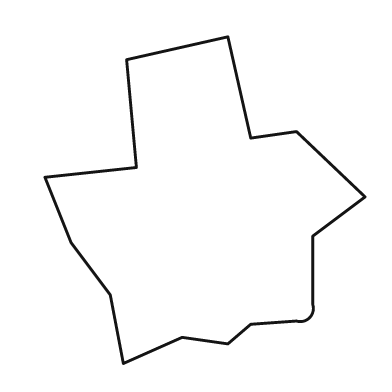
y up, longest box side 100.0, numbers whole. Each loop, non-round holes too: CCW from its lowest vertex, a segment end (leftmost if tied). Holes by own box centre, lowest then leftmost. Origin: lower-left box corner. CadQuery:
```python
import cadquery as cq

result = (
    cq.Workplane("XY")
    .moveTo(24.0, 0.0)
    .lineTo(42.0, 8.0)
    .lineTo(56.0, 6.0)
    .lineTo(63.0, 12.0)
    .lineTo(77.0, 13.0)
    .threePointArc((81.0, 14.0), (82.0, 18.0))
    .lineTo(82.0, 39.0)
    .lineTo(98.0, 51.0)
    .lineTo(77.0, 71.0)
    .lineTo(63.0, 69.0)
    .lineTo(56.0, 100.0)
    .lineTo(25.0, 93.0)
    .lineTo(28.0, 60.0)
    .lineTo(0.0, 57.0)
    .lineTo(8.0, 37.0)
    .lineTo(20.0, 21.0)
    .close()
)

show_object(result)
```